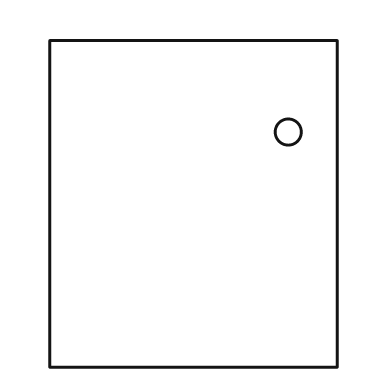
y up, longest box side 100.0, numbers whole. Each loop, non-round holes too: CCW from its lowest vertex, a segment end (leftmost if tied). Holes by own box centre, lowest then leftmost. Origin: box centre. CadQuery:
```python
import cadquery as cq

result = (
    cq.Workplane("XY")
    .moveTo(-44.0, -50.0)
    .lineTo(44.0, -50.0)
    .lineTo(44.0, 50.0)
    .lineTo(-44.0, 50.0)
    .close()
    .moveTo(29.0, 22.0)
    .circle(4.0)
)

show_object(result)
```